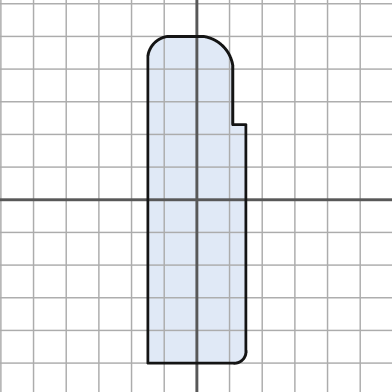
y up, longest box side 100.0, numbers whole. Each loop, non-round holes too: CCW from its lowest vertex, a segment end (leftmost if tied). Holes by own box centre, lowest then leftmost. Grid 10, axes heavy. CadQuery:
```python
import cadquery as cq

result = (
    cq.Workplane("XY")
    .moveTo(-15.0, -50.0)
    .lineTo(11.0, -50.0)
    .threePointArc((14.0, -49.0), (15.0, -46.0))
    .lineTo(15.0, 23.0)
    .lineTo(11.0, 23.0)
    .lineTo(11.0, 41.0)
    .threePointArc((8.0, 47.0), (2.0, 50.0))
    .lineTo(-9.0, 50.0)
    .threePointArc((-13.0, 48.0), (-15.0, 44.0))
    .close()
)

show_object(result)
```